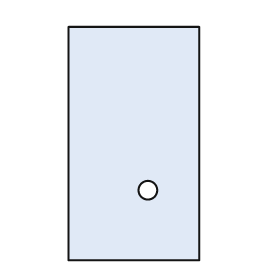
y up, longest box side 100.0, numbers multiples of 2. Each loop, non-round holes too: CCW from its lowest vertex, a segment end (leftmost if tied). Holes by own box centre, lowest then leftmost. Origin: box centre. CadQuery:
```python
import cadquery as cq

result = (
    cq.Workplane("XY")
    .moveTo(-28.0, -50.0)
    .lineTo(28.0, -50.0)
    .lineTo(28.0, 50.0)
    .lineTo(-28.0, 50.0)
    .close()
    .moveTo(6.0, -20.0)
    .circle(4.0)
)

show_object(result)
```